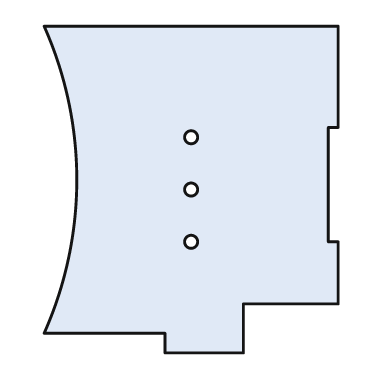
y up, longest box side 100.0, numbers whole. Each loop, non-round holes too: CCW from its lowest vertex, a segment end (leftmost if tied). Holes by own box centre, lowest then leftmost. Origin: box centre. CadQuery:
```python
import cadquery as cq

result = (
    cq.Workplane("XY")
    .moveTo(-8.0, -50.0)
    .lineTo(16.0, -50.0)
    .lineTo(16.0, -35.0)
    .lineTo(45.0, -35.0)
    .lineTo(45.0, -16.0)
    .lineTo(42.0, -16.0)
    .lineTo(42.0, 19.0)
    .lineTo(45.0, 19.0)
    .lineTo(45.0, 50.0)
    .lineTo(-45.0, 50.0)
    .threePointArc((-35.0, 3.0), (-45.0, -44.0))
    .lineTo(-8.0, -44.0)
    .close()
    .moveTo(0.0, -16.0)
    .circle(2.0)
    .moveTo(0.0, 0.0)
    .circle(2.0)
    .moveTo(0.0, 16.0)
    .circle(2.0)
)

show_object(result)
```